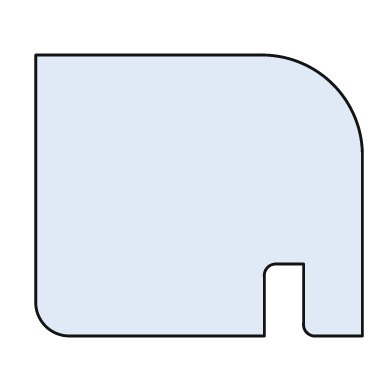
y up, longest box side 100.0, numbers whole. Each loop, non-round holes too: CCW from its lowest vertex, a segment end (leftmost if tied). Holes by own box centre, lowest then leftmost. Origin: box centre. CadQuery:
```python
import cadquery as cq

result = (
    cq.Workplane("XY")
    .moveTo(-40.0, -43.0)
    .lineTo(20.0, -43.0)
    .lineTo(20.0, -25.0)
    .threePointArc((21.0, -22.0), (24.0, -21.0))
    .lineTo(32.0, -21.0)
    .lineTo(32.0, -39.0)
    .threePointArc((33.0, -42.0), (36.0, -43.0))
    .lineTo(50.0, -43.0)
    .lineTo(50.0, 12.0)
    .threePointArc((41.0, 34.0), (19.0, 43.0))
    .lineTo(-50.0, 43.0)
    .lineTo(-50.0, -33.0)
    .threePointArc((-47.0, -40.0), (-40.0, -43.0))
    .close()
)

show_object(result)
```